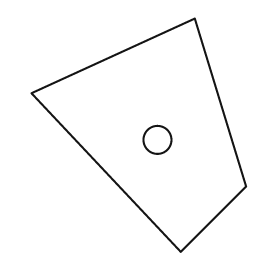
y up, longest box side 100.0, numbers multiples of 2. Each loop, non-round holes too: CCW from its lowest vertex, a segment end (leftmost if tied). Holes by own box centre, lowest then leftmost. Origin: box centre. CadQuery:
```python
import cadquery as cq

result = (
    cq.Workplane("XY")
    .moveTo(18.0, -50.0)
    .lineTo(46.0, -22.0)
    .lineTo(24.0, 50.0)
    .lineTo(-46.0, 18.0)
    .close()
    .moveTo(8.0, -2.0)
    .circle(6.0)
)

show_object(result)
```